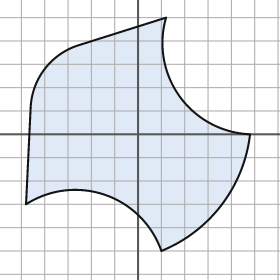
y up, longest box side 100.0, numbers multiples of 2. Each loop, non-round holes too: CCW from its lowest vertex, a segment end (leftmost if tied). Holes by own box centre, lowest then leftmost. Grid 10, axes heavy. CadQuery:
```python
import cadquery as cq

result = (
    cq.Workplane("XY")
    .moveTo(10.0, -50.0)
    .threePointArc((36.0, -30.0), (48.0, 0.0))
    .threePointArc((18.0, 16.0), (12.0, 50.0))
    .lineTo(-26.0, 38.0)
    .threePointArc((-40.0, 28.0), (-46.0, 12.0))
    .lineTo(-48.0, -30.0)
    .threePointArc((-14.0, -26.0), (10.0, -50.0))
    .close()
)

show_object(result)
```